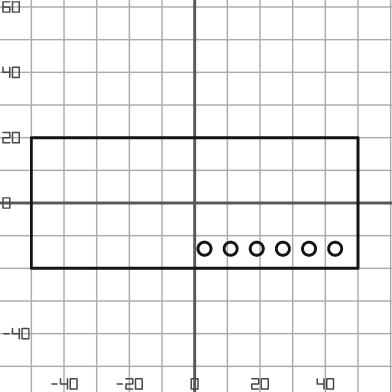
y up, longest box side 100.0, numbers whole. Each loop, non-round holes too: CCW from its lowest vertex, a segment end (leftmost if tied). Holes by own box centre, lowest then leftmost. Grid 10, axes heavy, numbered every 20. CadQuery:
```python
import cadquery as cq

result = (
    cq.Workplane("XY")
    .moveTo(-50.0, -20.0)
    .lineTo(50.0, -20.0)
    .lineTo(50.0, 20.0)
    .lineTo(-50.0, 20.0)
    .close()
    .moveTo(3.0, -14.0)
    .circle(2.0)
    .moveTo(11.0, -14.0)
    .circle(2.0)
    .moveTo(19.0, -14.0)
    .circle(2.0)
    .moveTo(27.0, -14.0)
    .circle(2.0)
    .moveTo(35.0, -14.0)
    .circle(2.0)
    .moveTo(43.0, -14.0)
    .circle(2.0)
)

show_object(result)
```